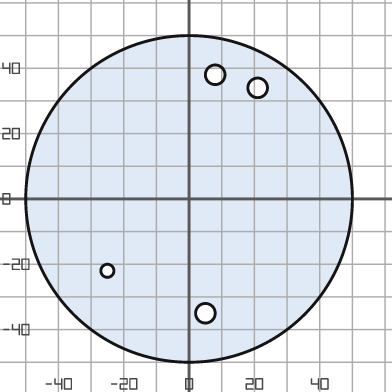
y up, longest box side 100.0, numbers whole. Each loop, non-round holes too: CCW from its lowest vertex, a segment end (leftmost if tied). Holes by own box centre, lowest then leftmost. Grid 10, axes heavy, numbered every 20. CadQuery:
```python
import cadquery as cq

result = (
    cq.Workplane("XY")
    .moveTo(0.0, 0.0)
    .circle(50.0)
    .moveTo(5.0, -35.0)
    .circle(3.0)
    .moveTo(-25.0, -22.0)
    .circle(2.0)
    .moveTo(21.0, 34.0)
    .circle(3.0)
    .moveTo(8.0, 38.0)
    .circle(3.0)
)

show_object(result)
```